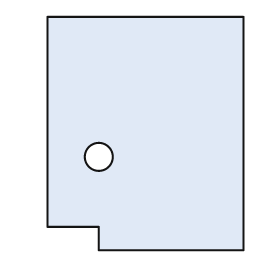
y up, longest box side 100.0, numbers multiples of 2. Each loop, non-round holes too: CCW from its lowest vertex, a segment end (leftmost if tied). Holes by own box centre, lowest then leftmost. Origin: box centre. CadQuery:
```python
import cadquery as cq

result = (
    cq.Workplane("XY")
    .moveTo(-20.0, -50.0)
    .lineTo(42.0, -50.0)
    .lineTo(42.0, 50.0)
    .lineTo(-42.0, 50.0)
    .lineTo(-42.0, -40.0)
    .lineTo(-20.0, -40.0)
    .close()
    .moveTo(-20.0, -10.0)
    .circle(6.0)
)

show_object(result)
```